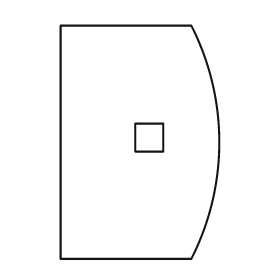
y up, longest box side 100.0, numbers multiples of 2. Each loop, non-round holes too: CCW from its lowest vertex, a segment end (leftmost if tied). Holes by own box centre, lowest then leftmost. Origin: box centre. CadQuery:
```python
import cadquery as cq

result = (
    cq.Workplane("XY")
    .moveTo(-34.0, -50.0)
    .lineTo(22.0, -50.0)
    .threePointArc((34.0, 0.0), (22.0, 50.0))
    .lineTo(-34.0, 50.0)
    .close()
    .moveTo(-2.0, -4.0)
    .lineTo(10.0, -4.0)
    .lineTo(10.0, 8.0)
    .lineTo(-2.0, 8.0)
    .close()
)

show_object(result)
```